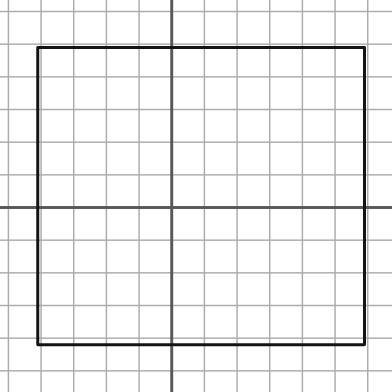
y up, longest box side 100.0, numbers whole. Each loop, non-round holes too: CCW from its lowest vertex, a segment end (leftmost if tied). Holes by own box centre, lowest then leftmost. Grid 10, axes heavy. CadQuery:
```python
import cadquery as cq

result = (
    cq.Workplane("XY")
    .moveTo(-41.0, -42.0)
    .lineTo(59.0, -42.0)
    .lineTo(59.0, 49.0)
    .lineTo(-41.0, 49.0)
    .close()
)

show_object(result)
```